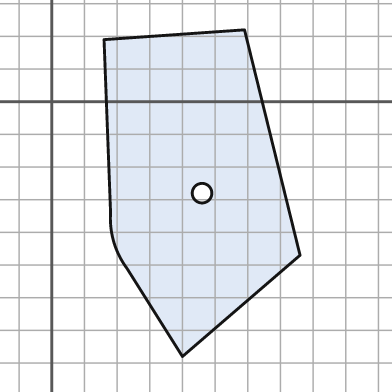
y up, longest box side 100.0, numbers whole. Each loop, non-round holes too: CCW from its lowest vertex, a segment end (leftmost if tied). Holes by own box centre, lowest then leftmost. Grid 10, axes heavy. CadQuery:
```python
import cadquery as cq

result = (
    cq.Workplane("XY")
    .moveTo(40.0, -78.0)
    .lineTo(76.0, -47.0)
    .lineTo(59.0, 22.0)
    .lineTo(16.0, 19.0)
    .lineTo(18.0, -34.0)
    .threePointArc((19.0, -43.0), (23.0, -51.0))
    .close()
    .moveTo(46.0, -28.0)
    .circle(3.0)
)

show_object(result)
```